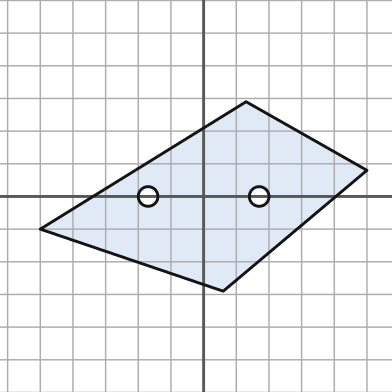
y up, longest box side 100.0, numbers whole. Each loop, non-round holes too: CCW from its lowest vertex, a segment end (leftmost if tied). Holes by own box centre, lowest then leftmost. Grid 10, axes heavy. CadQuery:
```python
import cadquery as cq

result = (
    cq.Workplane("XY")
    .moveTo(6.0, -29.0)
    .lineTo(50.0, 8.0)
    .lineTo(13.0, 29.0)
    .lineTo(-50.0, -10.0)
    .close()
    .moveTo(-17.0, 0.0)
    .circle(3.0)
    .moveTo(17.0, 0.0)
    .circle(3.0)
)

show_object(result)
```